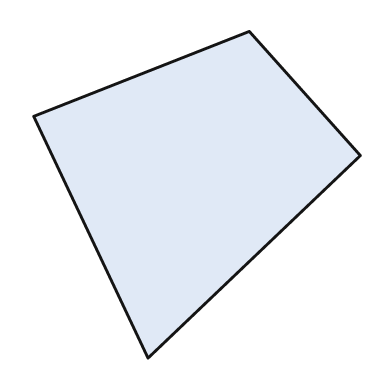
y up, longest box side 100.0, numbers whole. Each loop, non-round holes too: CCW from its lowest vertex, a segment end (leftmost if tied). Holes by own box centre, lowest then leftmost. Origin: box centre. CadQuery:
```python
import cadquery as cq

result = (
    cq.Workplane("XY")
    .moveTo(-15.0, -50.0)
    .lineTo(50.0, 12.0)
    .lineTo(16.0, 50.0)
    .lineTo(-50.0, 24.0)
    .close()
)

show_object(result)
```